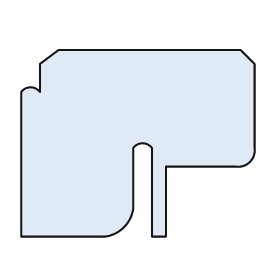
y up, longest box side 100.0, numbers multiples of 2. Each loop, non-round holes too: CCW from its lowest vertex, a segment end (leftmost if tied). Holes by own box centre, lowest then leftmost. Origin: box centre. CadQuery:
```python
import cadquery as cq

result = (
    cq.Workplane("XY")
    .moveTo(-50.0, -40.0)
    .lineTo(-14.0, -40.0)
    .threePointArc((-6.0, -36.0), (-2.0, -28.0))
    .lineTo(-2.0, -2.0)
    .threePointArc((2.0, 0.0), (6.0, -2.0))
    .lineTo(6.0, -40.0)
    .lineTo(12.0, -40.0)
    .lineTo(12.0, -10.0)
    .lineTo(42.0, -10.0)
    .threePointArc((48.0, -8.0), (50.0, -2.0))
    .lineTo(50.0, 34.0)
    .lineTo(44.0, 40.0)
    .lineTo(-34.0, 40.0)
    .lineTo(-42.0, 34.0)
    .lineTo(-42.0, 22.0)
    .threePointArc((-46.0, 24.0), (-50.0, 22.0))
    .close()
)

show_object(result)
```